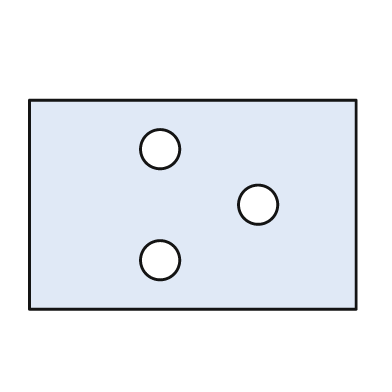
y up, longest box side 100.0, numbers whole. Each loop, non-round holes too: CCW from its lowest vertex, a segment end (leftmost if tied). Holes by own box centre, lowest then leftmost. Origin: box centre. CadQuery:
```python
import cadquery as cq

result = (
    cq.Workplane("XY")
    .moveTo(-50.0, -32.0)
    .lineTo(50.0, -32.0)
    .lineTo(50.0, 32.0)
    .lineTo(-50.0, 32.0)
    .close()
    .moveTo(-10.0, -17.0)
    .circle(6.0)
    .moveTo(20.0, 0.0)
    .circle(6.0)
    .moveTo(-10.0, 17.0)
    .circle(6.0)
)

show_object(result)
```